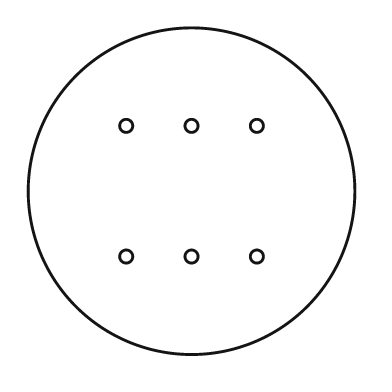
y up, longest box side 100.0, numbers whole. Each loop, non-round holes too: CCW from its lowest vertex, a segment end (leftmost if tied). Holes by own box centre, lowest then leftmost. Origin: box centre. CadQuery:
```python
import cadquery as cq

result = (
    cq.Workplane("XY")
    .moveTo(0.0, 0.0)
    .circle(50.0)
    .moveTo(-20.0, -20.0)
    .circle(2.0)
    .moveTo(0.0, -20.0)
    .circle(2.0)
    .moveTo(20.0, -20.0)
    .circle(2.0)
    .moveTo(-20.0, 20.0)
    .circle(2.0)
    .moveTo(0.0, 20.0)
    .circle(2.0)
    .moveTo(20.0, 20.0)
    .circle(2.0)
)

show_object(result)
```